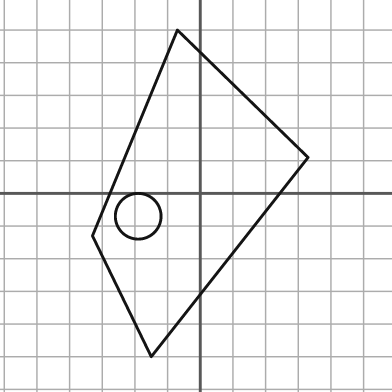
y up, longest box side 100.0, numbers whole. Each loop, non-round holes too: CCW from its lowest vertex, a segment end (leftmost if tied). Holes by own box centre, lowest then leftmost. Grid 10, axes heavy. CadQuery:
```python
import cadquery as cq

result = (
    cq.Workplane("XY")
    .moveTo(-15.0, -50.0)
    .lineTo(33.0, 11.0)
    .lineTo(-7.0, 50.0)
    .lineTo(-33.0, -13.0)
    .close()
    .moveTo(-19.0, -7.0)
    .circle(7.0)
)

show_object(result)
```